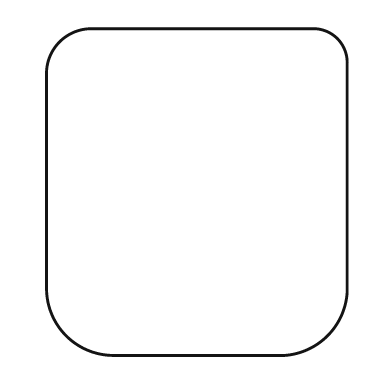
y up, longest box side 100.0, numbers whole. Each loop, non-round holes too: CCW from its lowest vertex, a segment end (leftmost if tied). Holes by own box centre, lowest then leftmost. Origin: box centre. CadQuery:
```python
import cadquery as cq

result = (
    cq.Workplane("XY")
    .moveTo(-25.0, -50.0)
    .lineTo(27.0, -50.0)
    .threePointArc((40.0, -44.0), (46.0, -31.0))
    .lineTo(46.0, 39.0)
    .threePointArc((43.0, 47.0), (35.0, 50.0))
    .lineTo(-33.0, 50.0)
    .threePointArc((-42.0, 46.0), (-46.0, 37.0))
    .lineTo(-46.0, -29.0)
    .threePointArc((-40.0, -44.0), (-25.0, -50.0))
    .close()
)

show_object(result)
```